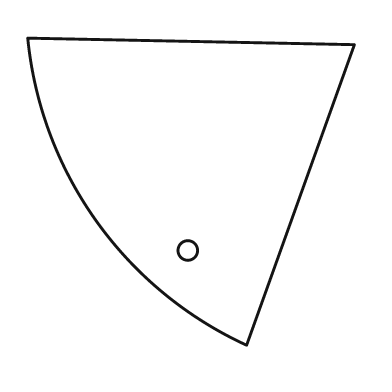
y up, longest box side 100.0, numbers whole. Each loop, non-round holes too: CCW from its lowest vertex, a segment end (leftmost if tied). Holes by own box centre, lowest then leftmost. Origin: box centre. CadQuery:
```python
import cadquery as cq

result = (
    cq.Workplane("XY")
    .moveTo(17.0, -47.0)
    .lineTo(50.0, 45.0)
    .lineTo(-50.0, 47.0)
    .threePointArc((-29.0, -9.0), (17.0, -47.0))
    .close()
    .moveTo(-1.0, -18.0)
    .circle(3.0)
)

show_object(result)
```